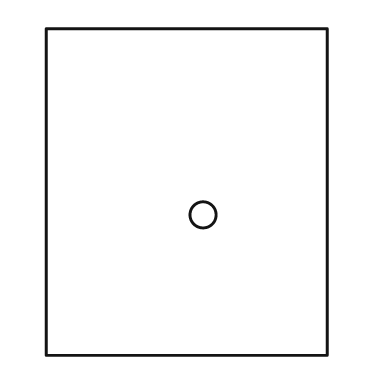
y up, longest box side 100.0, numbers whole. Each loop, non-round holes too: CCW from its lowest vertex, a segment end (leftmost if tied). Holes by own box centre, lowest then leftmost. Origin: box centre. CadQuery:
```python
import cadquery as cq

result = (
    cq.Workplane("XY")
    .moveTo(-43.0, -50.0)
    .lineTo(43.0, -50.0)
    .lineTo(43.0, 50.0)
    .lineTo(-43.0, 50.0)
    .close()
    .moveTo(5.0, -7.0)
    .circle(4.0)
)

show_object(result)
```